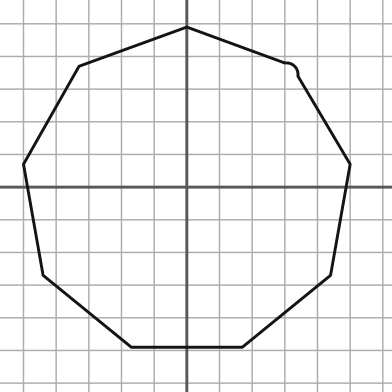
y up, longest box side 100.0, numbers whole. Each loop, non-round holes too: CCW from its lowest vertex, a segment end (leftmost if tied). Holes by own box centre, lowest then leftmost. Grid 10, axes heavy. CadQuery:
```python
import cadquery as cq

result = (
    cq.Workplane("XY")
    .moveTo(-17.0, -49.0)
    .lineTo(17.0, -49.0)
    .lineTo(44.0, -27.0)
    .lineTo(50.0, 7.0)
    .lineTo(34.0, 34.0)
    .threePointArc((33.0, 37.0), (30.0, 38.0))
    .lineTo(0.0, 49.0)
    .lineTo(-33.0, 37.0)
    .lineTo(-50.0, 7.0)
    .lineTo(-44.0, -27.0)
    .close()
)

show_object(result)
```